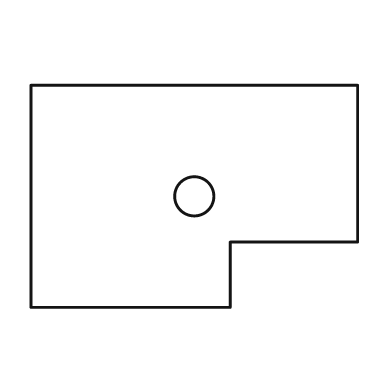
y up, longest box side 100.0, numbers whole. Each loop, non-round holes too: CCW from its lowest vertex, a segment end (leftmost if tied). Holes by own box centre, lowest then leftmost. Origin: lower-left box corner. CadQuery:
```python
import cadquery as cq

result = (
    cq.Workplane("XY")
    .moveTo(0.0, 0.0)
    .lineTo(61.0, 0.0)
    .lineTo(61.0, 20.0)
    .lineTo(100.0, 20.0)
    .lineTo(100.0, 68.0)
    .lineTo(0.0, 68.0)
    .close()
    .moveTo(50.0, 34.0)
    .circle(6.0)
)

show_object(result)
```